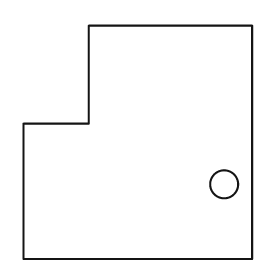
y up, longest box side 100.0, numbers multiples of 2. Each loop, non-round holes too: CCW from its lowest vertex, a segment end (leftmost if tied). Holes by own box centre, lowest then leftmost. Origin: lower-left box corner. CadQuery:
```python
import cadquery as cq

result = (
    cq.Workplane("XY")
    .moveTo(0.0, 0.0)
    .lineTo(98.0, 0.0)
    .lineTo(98.0, 100.0)
    .lineTo(28.0, 100.0)
    .lineTo(28.0, 58.0)
    .lineTo(0.0, 58.0)
    .close()
    .moveTo(86.0, 32.0)
    .circle(6.0)
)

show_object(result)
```